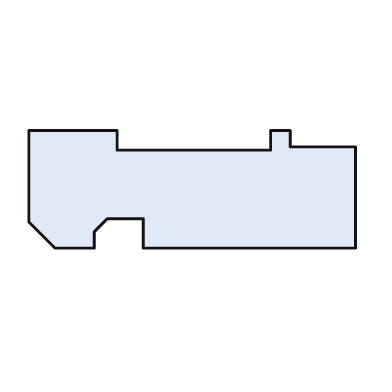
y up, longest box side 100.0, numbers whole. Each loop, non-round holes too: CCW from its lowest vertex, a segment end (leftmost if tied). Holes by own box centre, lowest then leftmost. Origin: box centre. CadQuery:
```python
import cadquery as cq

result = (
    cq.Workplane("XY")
    .moveTo(-42.0, -18.0)
    .lineTo(-30.0, -18.0)
    .lineTo(-30.0, -13.0)
    .lineTo(-26.0, -9.0)
    .lineTo(-15.0, -9.0)
    .lineTo(-15.0, -18.0)
    .lineTo(50.0, -18.0)
    .lineTo(50.0, 13.0)
    .lineTo(30.0, 13.0)
    .lineTo(30.0, 18.0)
    .lineTo(24.0, 18.0)
    .lineTo(24.0, 12.0)
    .lineTo(-23.0, 12.0)
    .lineTo(-23.0, 18.0)
    .lineTo(-50.0, 18.0)
    .lineTo(-50.0, -10.0)
    .close()
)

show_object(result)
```